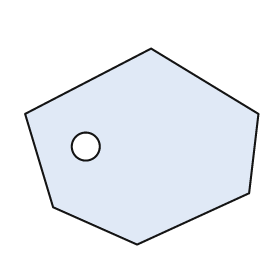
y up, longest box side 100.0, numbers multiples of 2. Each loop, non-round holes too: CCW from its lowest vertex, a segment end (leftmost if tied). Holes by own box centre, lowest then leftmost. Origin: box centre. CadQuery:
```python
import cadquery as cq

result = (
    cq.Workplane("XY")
    .moveTo(-2.0, -42.0)
    .lineTo(46.0, -20.0)
    .lineTo(50.0, 14.0)
    .lineTo(4.0, 42.0)
    .lineTo(-50.0, 14.0)
    .lineTo(-38.0, -26.0)
    .close()
    .moveTo(-24.0, 0.0)
    .circle(6.0)
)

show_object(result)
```